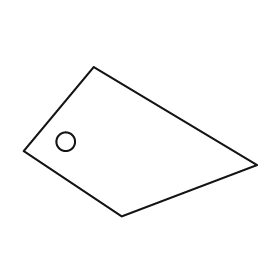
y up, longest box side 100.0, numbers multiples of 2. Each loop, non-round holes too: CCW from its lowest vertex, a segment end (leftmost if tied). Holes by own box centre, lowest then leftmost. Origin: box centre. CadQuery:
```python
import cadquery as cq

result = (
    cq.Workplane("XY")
    .moveTo(-8.0, -32.0)
    .lineTo(50.0, -10.0)
    .lineTo(-20.0, 32.0)
    .lineTo(-50.0, -4.0)
    .close()
    .moveTo(-32.0, 0.0)
    .circle(4.0)
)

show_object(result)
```